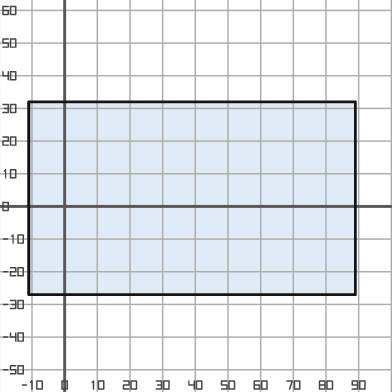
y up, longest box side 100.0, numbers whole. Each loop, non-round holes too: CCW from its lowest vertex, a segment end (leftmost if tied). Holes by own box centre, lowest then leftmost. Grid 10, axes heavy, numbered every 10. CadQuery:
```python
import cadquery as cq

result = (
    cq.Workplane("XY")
    .moveTo(-11.0, -27.0)
    .lineTo(89.0, -27.0)
    .lineTo(89.0, 32.0)
    .lineTo(-11.0, 32.0)
    .close()
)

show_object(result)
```